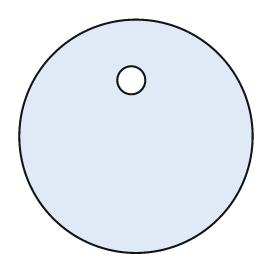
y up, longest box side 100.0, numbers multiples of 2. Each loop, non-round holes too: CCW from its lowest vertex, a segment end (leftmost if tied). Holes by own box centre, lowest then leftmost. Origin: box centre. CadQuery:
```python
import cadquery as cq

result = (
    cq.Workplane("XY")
    .moveTo(0.0, 0.0)
    .circle(50.0)
    .moveTo(-2.0, 24.0)
    .circle(6.0)
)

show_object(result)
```